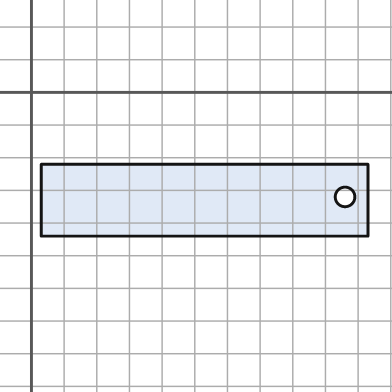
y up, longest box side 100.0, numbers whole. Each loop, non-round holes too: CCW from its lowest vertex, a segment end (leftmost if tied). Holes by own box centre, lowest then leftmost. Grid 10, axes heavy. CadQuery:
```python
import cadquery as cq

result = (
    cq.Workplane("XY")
    .moveTo(3.0, -44.0)
    .lineTo(103.0, -44.0)
    .lineTo(103.0, -22.0)
    .lineTo(3.0, -22.0)
    .close()
    .moveTo(96.0, -32.0)
    .circle(3.0)
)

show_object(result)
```